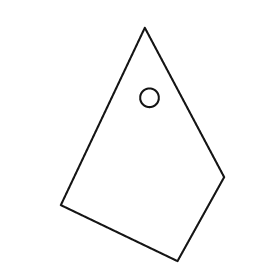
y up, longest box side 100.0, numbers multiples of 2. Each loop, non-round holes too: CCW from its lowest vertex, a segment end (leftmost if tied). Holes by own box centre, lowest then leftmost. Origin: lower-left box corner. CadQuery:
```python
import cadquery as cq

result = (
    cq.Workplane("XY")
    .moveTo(50.0, 0.0)
    .lineTo(70.0, 36.0)
    .lineTo(36.0, 100.0)
    .lineTo(0.0, 24.0)
    .close()
    .moveTo(38.0, 70.0)
    .circle(4.0)
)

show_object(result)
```